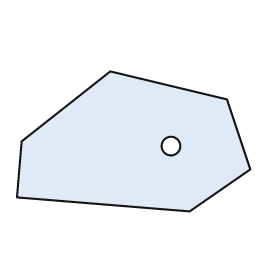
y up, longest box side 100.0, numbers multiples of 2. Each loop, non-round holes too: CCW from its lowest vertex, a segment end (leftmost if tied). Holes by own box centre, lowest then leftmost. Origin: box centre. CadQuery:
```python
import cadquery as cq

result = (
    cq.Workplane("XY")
    .moveTo(24.0, -30.0)
    .lineTo(50.0, -12.0)
    .lineTo(40.0, 18.0)
    .lineTo(-10.0, 30.0)
    .lineTo(-48.0, 0.0)
    .lineTo(-50.0, -24.0)
    .close()
    .moveTo(16.0, -2.0)
    .circle(4.0)
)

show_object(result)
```